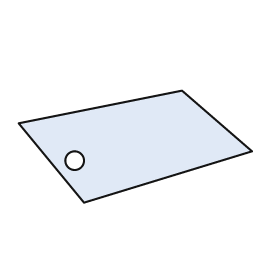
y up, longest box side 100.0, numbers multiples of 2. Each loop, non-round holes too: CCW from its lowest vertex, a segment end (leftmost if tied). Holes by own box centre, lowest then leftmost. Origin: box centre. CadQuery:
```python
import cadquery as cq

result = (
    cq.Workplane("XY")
    .moveTo(-22.0, -24.0)
    .lineTo(50.0, -2.0)
    .lineTo(20.0, 24.0)
    .lineTo(-50.0, 10.0)
    .close()
    .moveTo(-26.0, -6.0)
    .circle(4.0)
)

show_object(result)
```